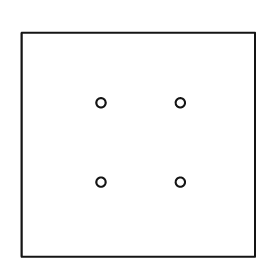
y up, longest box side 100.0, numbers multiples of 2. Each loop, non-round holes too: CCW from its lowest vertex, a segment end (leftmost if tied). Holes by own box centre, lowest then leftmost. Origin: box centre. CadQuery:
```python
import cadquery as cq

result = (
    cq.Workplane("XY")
    .moveTo(-50.0, -48.0)
    .lineTo(50.0, -48.0)
    .lineTo(50.0, 48.0)
    .lineTo(-50.0, 48.0)
    .close()
    .moveTo(-16.0, -16.0)
    .circle(2.0)
    .moveTo(18.0, -16.0)
    .circle(2.0)
    .moveTo(-16.0, 18.0)
    .circle(2.0)
    .moveTo(18.0, 18.0)
    .circle(2.0)
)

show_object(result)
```